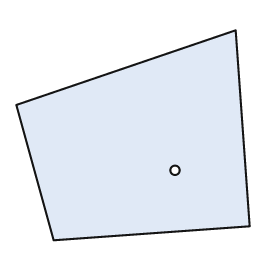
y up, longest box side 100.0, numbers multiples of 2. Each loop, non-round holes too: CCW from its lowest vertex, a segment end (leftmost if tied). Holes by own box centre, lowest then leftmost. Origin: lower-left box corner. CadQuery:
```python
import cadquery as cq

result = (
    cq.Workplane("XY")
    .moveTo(16.0, 0.0)
    .lineTo(100.0, 6.0)
    .lineTo(94.0, 90.0)
    .lineTo(0.0, 58.0)
    .close()
    .moveTo(68.0, 30.0)
    .circle(2.0)
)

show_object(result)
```